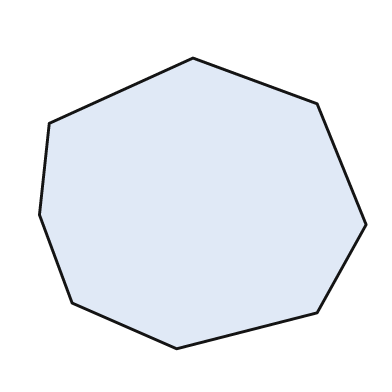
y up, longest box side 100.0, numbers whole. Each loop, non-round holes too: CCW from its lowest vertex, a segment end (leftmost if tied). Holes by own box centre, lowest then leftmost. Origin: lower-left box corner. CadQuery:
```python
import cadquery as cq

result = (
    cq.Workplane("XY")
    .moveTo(42.0, 0.0)
    .lineTo(85.0, 11.0)
    .lineTo(100.0, 38.0)
    .lineTo(85.0, 75.0)
    .lineTo(47.0, 89.0)
    .lineTo(3.0, 69.0)
    .lineTo(0.0, 41.0)
    .lineTo(10.0, 14.0)
    .close()
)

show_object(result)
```